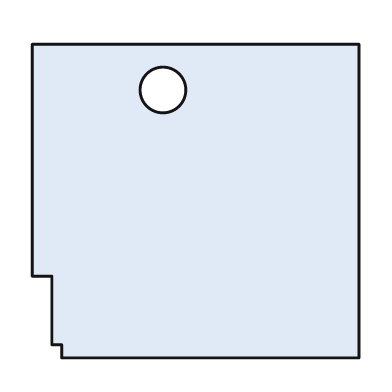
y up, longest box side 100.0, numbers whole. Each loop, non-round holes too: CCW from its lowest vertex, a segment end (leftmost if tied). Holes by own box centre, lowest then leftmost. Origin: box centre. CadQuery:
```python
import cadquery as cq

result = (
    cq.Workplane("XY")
    .moveTo(-41.0, -48.0)
    .lineTo(50.0, -48.0)
    .lineTo(50.0, 48.0)
    .lineTo(-50.0, 48.0)
    .lineTo(-50.0, -23.0)
    .lineTo(-44.0, -23.0)
    .lineTo(-44.0, -44.0)
    .lineTo(-41.0, -44.0)
    .close()
    .moveTo(-10.0, 34.0)
    .circle(7.0)
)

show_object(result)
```